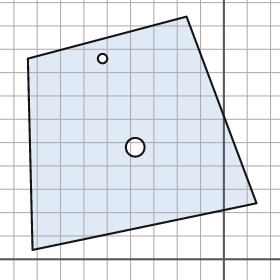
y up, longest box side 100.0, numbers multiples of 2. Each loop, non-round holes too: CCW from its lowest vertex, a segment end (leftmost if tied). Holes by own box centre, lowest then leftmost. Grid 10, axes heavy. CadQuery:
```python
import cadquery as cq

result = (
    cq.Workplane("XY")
    .moveTo(-82.0, 4.0)
    .lineTo(14.0, 24.0)
    .lineTo(-16.0, 104.0)
    .lineTo(-84.0, 86.0)
    .close()
    .moveTo(-38.0, 48.0)
    .circle(4.0)
    .moveTo(-52.0, 86.0)
    .circle(2.0)
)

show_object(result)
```